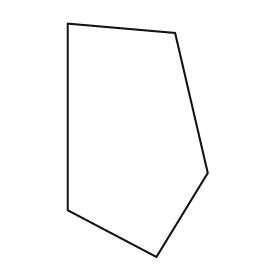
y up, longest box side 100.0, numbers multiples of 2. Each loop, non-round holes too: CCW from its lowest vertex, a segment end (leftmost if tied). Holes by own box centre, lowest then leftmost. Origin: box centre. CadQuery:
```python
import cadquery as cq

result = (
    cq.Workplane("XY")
    .moveTo(8.0, -50.0)
    .lineTo(30.0, -14.0)
    .lineTo(16.0, 46.0)
    .lineTo(-30.0, 50.0)
    .lineTo(-30.0, -30.0)
    .close()
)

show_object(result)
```